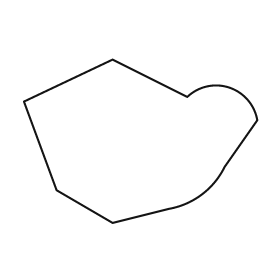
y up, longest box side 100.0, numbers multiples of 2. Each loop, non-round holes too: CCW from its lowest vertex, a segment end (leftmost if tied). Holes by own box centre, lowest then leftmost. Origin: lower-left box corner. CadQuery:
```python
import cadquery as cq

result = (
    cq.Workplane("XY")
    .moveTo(38.0, 0.0)
    .lineTo(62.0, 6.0)
    .threePointArc((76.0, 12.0), (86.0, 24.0))
    .lineTo(100.0, 44.0)
    .threePointArc((88.0, 58.0), (70.0, 54.0))
    .lineTo(38.0, 70.0)
    .lineTo(0.0, 52.0)
    .lineTo(14.0, 14.0)
    .close()
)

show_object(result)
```